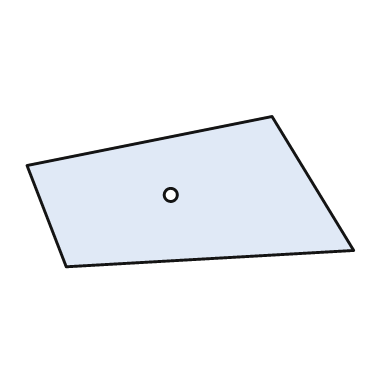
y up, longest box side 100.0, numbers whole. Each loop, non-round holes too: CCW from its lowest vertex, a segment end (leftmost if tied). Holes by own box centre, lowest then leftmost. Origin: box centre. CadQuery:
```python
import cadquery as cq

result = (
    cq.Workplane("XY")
    .moveTo(-38.0, -23.0)
    .lineTo(50.0, -18.0)
    .lineTo(25.0, 23.0)
    .lineTo(-50.0, 8.0)
    .close()
    .moveTo(-6.0, -1.0)
    .circle(2.0)
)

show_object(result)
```